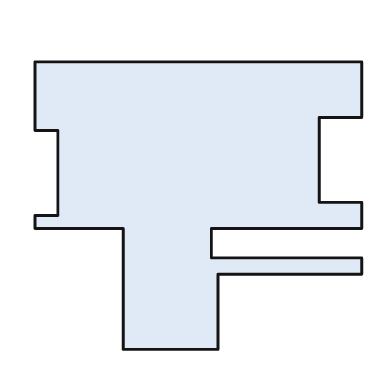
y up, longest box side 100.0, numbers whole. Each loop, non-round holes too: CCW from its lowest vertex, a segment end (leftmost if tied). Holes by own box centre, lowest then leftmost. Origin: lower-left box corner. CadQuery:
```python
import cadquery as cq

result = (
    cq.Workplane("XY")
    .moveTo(27.0, 0.0)
    .lineTo(56.0, 0.0)
    .lineTo(56.0, 23.0)
    .lineTo(100.0, 23.0)
    .lineTo(100.0, 28.0)
    .lineTo(54.0, 28.0)
    .lineTo(54.0, 37.0)
    .lineTo(100.0, 37.0)
    .lineTo(100.0, 45.0)
    .lineTo(87.0, 45.0)
    .lineTo(87.0, 71.0)
    .lineTo(100.0, 71.0)
    .lineTo(100.0, 88.0)
    .lineTo(0.0, 88.0)
    .lineTo(0.0, 67.0)
    .lineTo(7.0, 67.0)
    .lineTo(7.0, 41.0)
    .lineTo(0.0, 41.0)
    .lineTo(0.0, 37.0)
    .lineTo(27.0, 37.0)
    .close()
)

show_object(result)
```